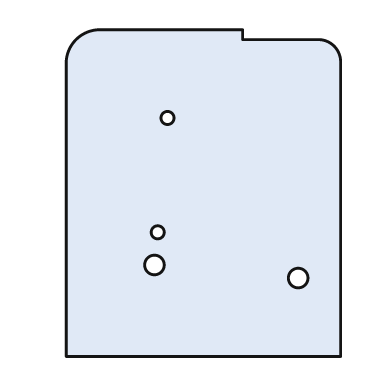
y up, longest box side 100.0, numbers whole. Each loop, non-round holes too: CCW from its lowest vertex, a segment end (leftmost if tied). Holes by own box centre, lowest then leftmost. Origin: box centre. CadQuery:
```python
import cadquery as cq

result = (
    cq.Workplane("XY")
    .moveTo(-42.0, -50.0)
    .lineTo(42.0, -50.0)
    .lineTo(42.0, 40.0)
    .threePointArc((40.0, 45.0), (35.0, 47.0))
    .lineTo(12.0, 47.0)
    .lineTo(12.0, 50.0)
    .lineTo(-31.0, 50.0)
    .threePointArc((-39.0, 47.0), (-42.0, 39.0))
    .close()
    .moveTo(29.0, -26.0)
    .circle(3.0)
    .moveTo(-15.0, -22.0)
    .circle(3.0)
    .moveTo(-14.0, -12.0)
    .circle(2.0)
    .moveTo(-11.0, 23.0)
    .circle(2.0)
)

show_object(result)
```